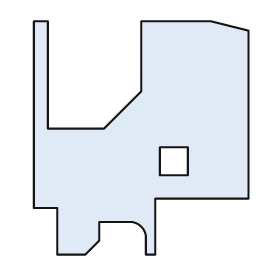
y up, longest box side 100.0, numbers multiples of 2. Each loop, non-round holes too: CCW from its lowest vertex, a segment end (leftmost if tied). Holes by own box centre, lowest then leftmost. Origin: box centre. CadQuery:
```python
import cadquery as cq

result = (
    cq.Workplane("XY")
    .moveTo(-36.0, -50.0)
    .lineTo(-24.0, -50.0)
    .lineTo(-18.0, -44.0)
    .lineTo(-18.0, -36.0)
    .lineTo(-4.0, -36.0)
    .threePointArc((0.0, -38.0), (2.0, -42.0))
    .lineTo(2.0, -50.0)
    .lineTo(6.0, -50.0)
    .lineTo(6.0, -26.0)
    .lineTo(46.0, -26.0)
    .lineTo(46.0, 46.0)
    .lineTo(30.0, 50.0)
    .lineTo(0.0, 50.0)
    .lineTo(0.0, 20.0)
    .lineTo(-16.0, 4.0)
    .lineTo(-40.0, 4.0)
    .lineTo(-40.0, 50.0)
    .lineTo(-46.0, 50.0)
    .lineTo(-46.0, -30.0)
    .lineTo(-36.0, -30.0)
    .close()
    .moveTo(8.0, -16.0)
    .lineTo(20.0, -16.0)
    .lineTo(20.0, -4.0)
    .lineTo(8.0, -4.0)
    .close()
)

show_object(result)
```